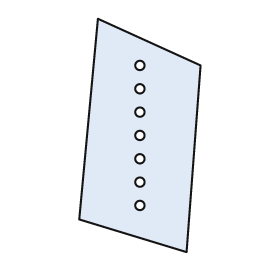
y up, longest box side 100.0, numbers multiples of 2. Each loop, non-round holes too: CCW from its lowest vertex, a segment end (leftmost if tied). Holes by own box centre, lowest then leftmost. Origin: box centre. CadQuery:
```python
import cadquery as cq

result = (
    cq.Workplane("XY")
    .moveTo(20.0, -50.0)
    .lineTo(26.0, 30.0)
    .lineTo(-18.0, 50.0)
    .lineTo(-26.0, -36.0)
    .close()
    .moveTo(0.0, -30.0)
    .circle(2.0)
    .moveTo(0.0, -20.0)
    .circle(2.0)
    .moveTo(0.0, -10.0)
    .circle(2.0)
    .moveTo(0.0, 0.0)
    .circle(2.0)
    .moveTo(0.0, 10.0)
    .circle(2.0)
    .moveTo(0.0, 20.0)
    .circle(2.0)
    .moveTo(0.0, 30.0)
    .circle(2.0)
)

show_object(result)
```